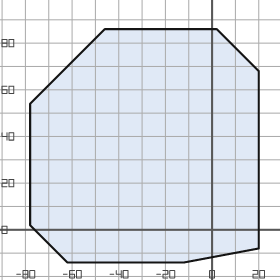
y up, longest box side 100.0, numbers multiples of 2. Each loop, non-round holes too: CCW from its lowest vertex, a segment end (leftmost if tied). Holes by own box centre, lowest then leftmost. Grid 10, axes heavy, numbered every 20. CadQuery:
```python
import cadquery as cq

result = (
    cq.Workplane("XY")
    .moveTo(-62.0, -14.0)
    .lineTo(-12.0, -14.0)
    .lineTo(20.0, -8.0)
    .lineTo(20.0, 68.0)
    .lineTo(2.0, 86.0)
    .lineTo(-46.0, 86.0)
    .lineTo(-78.0, 54.0)
    .lineTo(-78.0, 2.0)
    .close()
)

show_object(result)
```